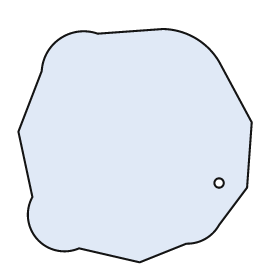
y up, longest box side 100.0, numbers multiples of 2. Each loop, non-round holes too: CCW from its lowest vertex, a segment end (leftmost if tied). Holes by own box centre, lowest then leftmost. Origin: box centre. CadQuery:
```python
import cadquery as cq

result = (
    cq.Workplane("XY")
    .moveTo(2.0, -50.0)
    .lineTo(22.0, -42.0)
    .threePointArc((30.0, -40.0), (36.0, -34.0))
    .lineTo(48.0, -18.0)
    .lineTo(50.0, 10.0)
    .lineTo(36.0, 36.0)
    .threePointArc((26.0, 46.0), (12.0, 50.0))
    .lineTo(-16.0, 48.0)
    .threePointArc((-32.0, 46.0), (-40.0, 32.0))
    .lineTo(-50.0, 6.0)
    .lineTo(-44.0, -22.0)
    .threePointArc((-42.0, -40.0), (-24.0, -44.0))
    .close()
    .moveTo(36.0, -16.0)
    .circle(2.0)
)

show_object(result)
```